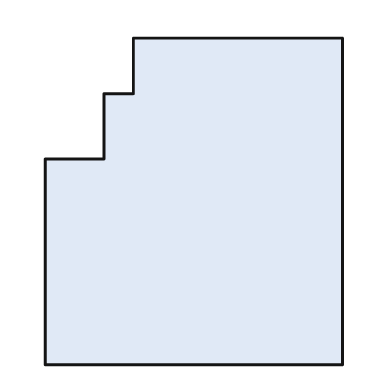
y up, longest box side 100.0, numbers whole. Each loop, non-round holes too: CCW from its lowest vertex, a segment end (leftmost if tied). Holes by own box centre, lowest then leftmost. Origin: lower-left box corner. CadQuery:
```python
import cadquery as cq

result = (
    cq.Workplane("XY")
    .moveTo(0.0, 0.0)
    .lineTo(91.0, 0.0)
    .lineTo(91.0, 100.0)
    .lineTo(27.0, 100.0)
    .lineTo(27.0, 83.0)
    .lineTo(18.0, 83.0)
    .lineTo(18.0, 63.0)
    .lineTo(0.0, 63.0)
    .close()
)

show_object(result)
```